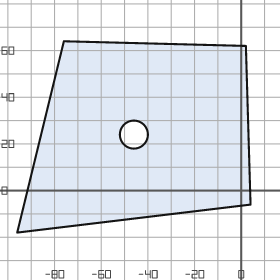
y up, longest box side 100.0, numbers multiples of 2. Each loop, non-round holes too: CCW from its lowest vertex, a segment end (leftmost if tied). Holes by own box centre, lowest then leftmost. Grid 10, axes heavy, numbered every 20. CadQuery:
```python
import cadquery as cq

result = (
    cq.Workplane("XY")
    .moveTo(-96.0, -18.0)
    .lineTo(4.0, -6.0)
    .lineTo(2.0, 62.0)
    .lineTo(-76.0, 64.0)
    .close()
    .moveTo(-46.0, 24.0)
    .circle(6.0)
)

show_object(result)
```